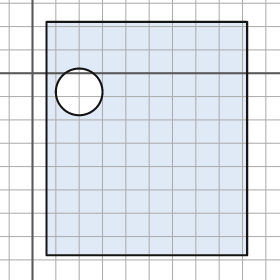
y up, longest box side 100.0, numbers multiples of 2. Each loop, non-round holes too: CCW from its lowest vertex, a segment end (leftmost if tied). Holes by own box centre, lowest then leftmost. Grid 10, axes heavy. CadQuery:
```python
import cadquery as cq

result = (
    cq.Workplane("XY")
    .moveTo(6.0, -78.0)
    .lineTo(92.0, -78.0)
    .lineTo(92.0, 22.0)
    .lineTo(6.0, 22.0)
    .close()
    .moveTo(20.0, -8.0)
    .circle(10.0)
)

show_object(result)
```